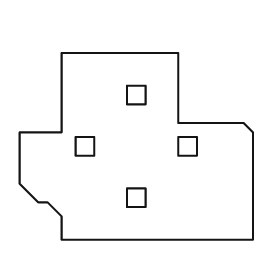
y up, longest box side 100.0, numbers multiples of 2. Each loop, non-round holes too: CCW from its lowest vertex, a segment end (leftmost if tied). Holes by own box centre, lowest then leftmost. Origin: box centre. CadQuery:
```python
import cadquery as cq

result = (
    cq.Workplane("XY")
    .moveTo(-32.0, -40.0)
    .lineTo(50.0, -40.0)
    .lineTo(50.0, 6.0)
    .lineTo(46.0, 10.0)
    .lineTo(18.0, 10.0)
    .lineTo(18.0, 40.0)
    .lineTo(-32.0, 40.0)
    .lineTo(-32.0, 6.0)
    .lineTo(-50.0, 6.0)
    .lineTo(-50.0, -16.0)
    .lineTo(-42.0, -24.0)
    .lineTo(-38.0, -24.0)
    .lineTo(-32.0, -30.0)
    .close()
    .moveTo(-4.0, -26.0)
    .lineTo(4.0, -26.0)
    .lineTo(4.0, -18.0)
    .lineTo(-4.0, -18.0)
    .close()
    .moveTo(-26.0, -4.0)
    .lineTo(-18.0, -4.0)
    .lineTo(-18.0, 4.0)
    .lineTo(-26.0, 4.0)
    .close()
    .moveTo(18.0, -4.0)
    .lineTo(26.0, -4.0)
    .lineTo(26.0, 4.0)
    .lineTo(18.0, 4.0)
    .close()
    .moveTo(-4.0, 18.0)
    .lineTo(4.0, 18.0)
    .lineTo(4.0, 26.0)
    .lineTo(-4.0, 26.0)
    .close()
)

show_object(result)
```